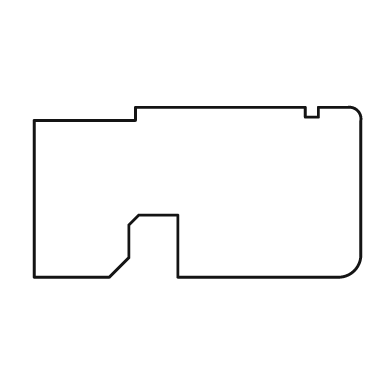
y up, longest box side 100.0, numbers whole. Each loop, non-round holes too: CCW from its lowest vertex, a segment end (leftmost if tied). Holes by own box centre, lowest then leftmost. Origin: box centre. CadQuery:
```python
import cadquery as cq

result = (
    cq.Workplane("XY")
    .moveTo(-50.0, -26.0)
    .lineTo(-27.0, -26.0)
    .lineTo(-21.0, -20.0)
    .lineTo(-21.0, -10.0)
    .lineTo(-18.0, -7.0)
    .lineTo(-6.0, -7.0)
    .lineTo(-6.0, -26.0)
    .lineTo(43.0, -26.0)
    .threePointArc((48.0, -24.0), (50.0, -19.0))
    .lineTo(50.0, 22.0)
    .threePointArc((49.0, 25.0), (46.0, 26.0))
    .lineTo(37.0, 26.0)
    .lineTo(37.0, 23.0)
    .lineTo(33.0, 23.0)
    .lineTo(33.0, 26.0)
    .lineTo(-19.0, 26.0)
    .lineTo(-19.0, 22.0)
    .lineTo(-50.0, 22.0)
    .close()
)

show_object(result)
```